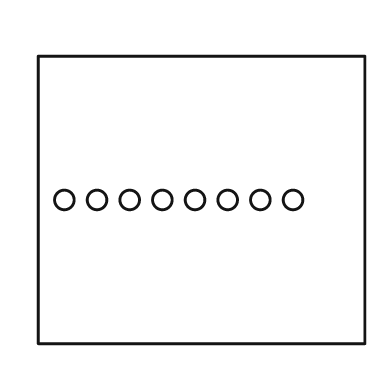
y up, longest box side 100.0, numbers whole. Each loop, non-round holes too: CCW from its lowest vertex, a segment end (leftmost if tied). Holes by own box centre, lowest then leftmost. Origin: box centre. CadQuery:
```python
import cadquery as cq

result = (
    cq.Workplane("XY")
    .moveTo(-50.0, -44.0)
    .lineTo(50.0, -44.0)
    .lineTo(50.0, 44.0)
    .lineTo(-50.0, 44.0)
    .close()
    .moveTo(-42.0, 0.0)
    .circle(3.0)
    .moveTo(-32.0, 0.0)
    .circle(3.0)
    .moveTo(-22.0, 0.0)
    .circle(3.0)
    .moveTo(-12.0, 0.0)
    .circle(3.0)
    .moveTo(-2.0, 0.0)
    .circle(3.0)
    .moveTo(8.0, 0.0)
    .circle(3.0)
    .moveTo(18.0, 0.0)
    .circle(3.0)
    .moveTo(28.0, 0.0)
    .circle(3.0)
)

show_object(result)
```